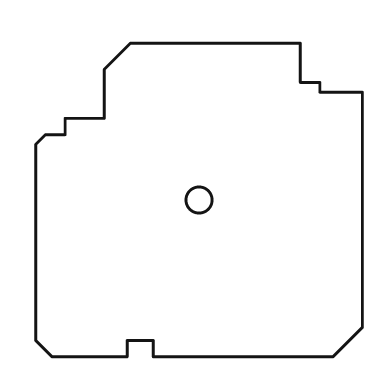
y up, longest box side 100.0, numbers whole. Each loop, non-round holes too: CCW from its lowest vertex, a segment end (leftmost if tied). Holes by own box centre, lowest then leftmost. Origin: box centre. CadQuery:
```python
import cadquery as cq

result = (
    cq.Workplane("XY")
    .moveTo(-45.0, -48.0)
    .lineTo(-22.0, -48.0)
    .lineTo(-22.0, -43.0)
    .lineTo(-14.0, -43.0)
    .lineTo(-14.0, -48.0)
    .lineTo(41.0, -48.0)
    .lineTo(50.0, -39.0)
    .lineTo(50.0, 33.0)
    .lineTo(37.0, 33.0)
    .lineTo(37.0, 36.0)
    .lineTo(31.0, 36.0)
    .lineTo(31.0, 48.0)
    .lineTo(-21.0, 48.0)
    .lineTo(-29.0, 40.0)
    .lineTo(-29.0, 25.0)
    .lineTo(-41.0, 25.0)
    .lineTo(-41.0, 20.0)
    .lineTo(-47.0, 20.0)
    .lineTo(-50.0, 17.0)
    .lineTo(-50.0, -43.0)
    .close()
    .moveTo(0.0, 0.0)
    .circle(4.0)
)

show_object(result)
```